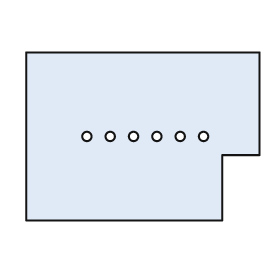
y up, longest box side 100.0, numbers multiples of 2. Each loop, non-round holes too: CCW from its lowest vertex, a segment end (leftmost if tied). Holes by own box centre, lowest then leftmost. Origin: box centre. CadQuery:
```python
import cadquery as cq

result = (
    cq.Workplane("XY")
    .moveTo(-50.0, -36.0)
    .lineTo(34.0, -36.0)
    .lineTo(34.0, -8.0)
    .lineTo(50.0, -8.0)
    .lineTo(50.0, 36.0)
    .lineTo(-50.0, 36.0)
    .close()
    .moveTo(-24.0, 0.0)
    .circle(2.0)
    .moveTo(-14.0, 0.0)
    .circle(2.0)
    .moveTo(-4.0, 0.0)
    .circle(2.0)
    .moveTo(6.0, 0.0)
    .circle(2.0)
    .moveTo(16.0, 0.0)
    .circle(2.0)
    .moveTo(26.0, 0.0)
    .circle(2.0)
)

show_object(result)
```